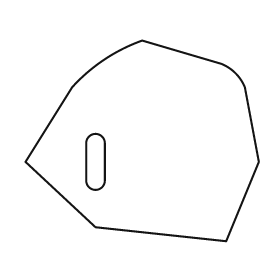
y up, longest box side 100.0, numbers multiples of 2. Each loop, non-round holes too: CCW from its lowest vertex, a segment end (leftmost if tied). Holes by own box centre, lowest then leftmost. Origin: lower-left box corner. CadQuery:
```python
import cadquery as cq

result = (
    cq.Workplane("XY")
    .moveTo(86.0, 0.0)
    .lineTo(100.0, 34.0)
    .lineTo(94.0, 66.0)
    .threePointArc((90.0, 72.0), (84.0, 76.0))
    .lineTo(50.0, 86.0)
    .threePointArc((34.0, 78.0), (20.0, 66.0))
    .lineTo(0.0, 34.0)
    .lineTo(30.0, 6.0)
    .close()
    .moveTo(26.0, 26.0)
    .threePointArc((30.0, 22.0), (34.0, 26.0))
    .lineTo(34.0, 42.0)
    .threePointArc((30.0, 46.0), (26.0, 42.0))
    .close()
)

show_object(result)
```